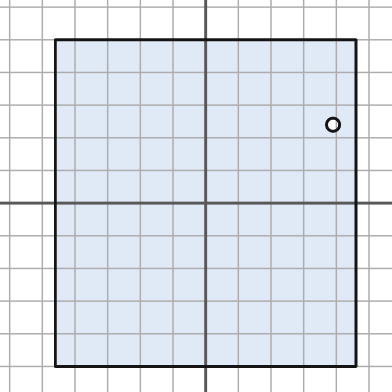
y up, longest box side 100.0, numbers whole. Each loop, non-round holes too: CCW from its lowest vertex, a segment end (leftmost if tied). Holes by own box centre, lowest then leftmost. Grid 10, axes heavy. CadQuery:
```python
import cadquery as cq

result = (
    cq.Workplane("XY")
    .moveTo(-46.0, -50.0)
    .lineTo(46.0, -50.0)
    .lineTo(46.0, 50.0)
    .lineTo(-46.0, 50.0)
    .close()
    .moveTo(39.0, 24.0)
    .circle(2.0)
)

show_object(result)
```